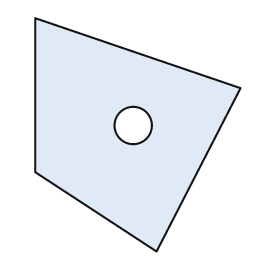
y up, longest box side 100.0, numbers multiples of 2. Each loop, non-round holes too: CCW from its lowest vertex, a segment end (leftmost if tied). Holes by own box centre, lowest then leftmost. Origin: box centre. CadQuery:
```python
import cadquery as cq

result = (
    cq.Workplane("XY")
    .moveTo(8.0, -50.0)
    .lineTo(44.0, 20.0)
    .lineTo(-44.0, 50.0)
    .lineTo(-44.0, -16.0)
    .close()
    .moveTo(-2.0, 4.0)
    .circle(8.0)
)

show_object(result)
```